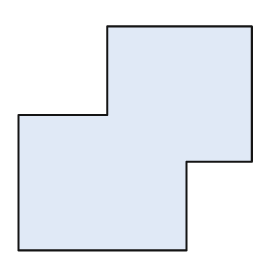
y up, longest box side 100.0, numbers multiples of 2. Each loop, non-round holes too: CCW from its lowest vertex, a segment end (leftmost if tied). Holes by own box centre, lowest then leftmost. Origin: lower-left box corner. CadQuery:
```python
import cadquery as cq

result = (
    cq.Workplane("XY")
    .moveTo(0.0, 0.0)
    .lineTo(72.0, 0.0)
    .lineTo(72.0, 38.0)
    .lineTo(100.0, 38.0)
    .lineTo(100.0, 96.0)
    .lineTo(38.0, 96.0)
    .lineTo(38.0, 58.0)
    .lineTo(0.0, 58.0)
    .close()
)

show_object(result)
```